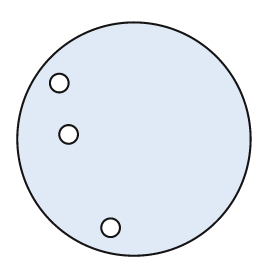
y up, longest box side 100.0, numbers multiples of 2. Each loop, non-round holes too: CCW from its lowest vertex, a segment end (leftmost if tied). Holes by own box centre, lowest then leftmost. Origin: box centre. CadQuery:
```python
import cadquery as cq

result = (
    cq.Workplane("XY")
    .moveTo(0.0, 0.0)
    .circle(50.0)
    .moveTo(-10.0, -38.0)
    .circle(4.0)
    .moveTo(-28.0, 2.0)
    .circle(4.0)
    .moveTo(-32.0, 24.0)
    .circle(4.0)
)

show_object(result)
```